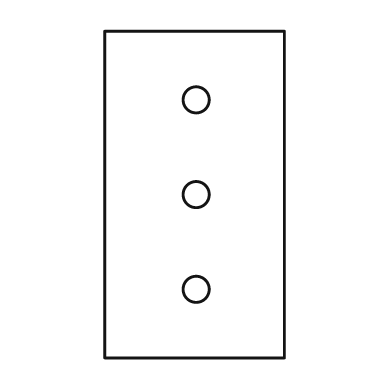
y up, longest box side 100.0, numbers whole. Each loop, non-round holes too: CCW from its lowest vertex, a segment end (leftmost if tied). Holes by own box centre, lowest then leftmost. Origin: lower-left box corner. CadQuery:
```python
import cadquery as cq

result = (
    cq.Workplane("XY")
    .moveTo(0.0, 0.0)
    .lineTo(55.0, 0.0)
    .lineTo(55.0, 100.0)
    .lineTo(0.0, 100.0)
    .close()
    .moveTo(28.0, 21.0)
    .circle(4.0)
    .moveTo(28.0, 50.0)
    .circle(4.0)
    .moveTo(28.0, 79.0)
    .circle(4.0)
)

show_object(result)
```